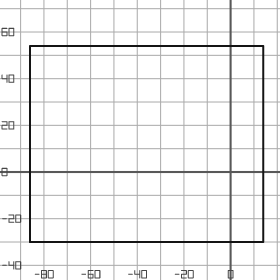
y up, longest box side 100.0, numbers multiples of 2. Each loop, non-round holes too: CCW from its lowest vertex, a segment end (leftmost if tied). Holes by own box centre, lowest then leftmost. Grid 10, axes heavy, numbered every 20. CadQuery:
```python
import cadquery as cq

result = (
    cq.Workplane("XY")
    .moveTo(-86.0, -30.0)
    .lineTo(14.0, -30.0)
    .lineTo(14.0, 54.0)
    .lineTo(-86.0, 54.0)
    .close()
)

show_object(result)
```